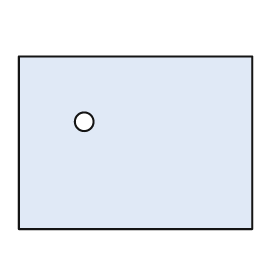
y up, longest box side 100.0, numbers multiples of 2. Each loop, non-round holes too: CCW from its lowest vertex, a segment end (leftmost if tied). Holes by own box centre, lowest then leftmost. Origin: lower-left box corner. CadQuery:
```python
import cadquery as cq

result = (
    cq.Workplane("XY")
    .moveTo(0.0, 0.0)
    .lineTo(100.0, 0.0)
    .lineTo(100.0, 74.0)
    .lineTo(0.0, 74.0)
    .close()
    .moveTo(28.0, 46.0)
    .circle(4.0)
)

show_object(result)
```